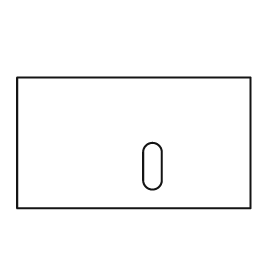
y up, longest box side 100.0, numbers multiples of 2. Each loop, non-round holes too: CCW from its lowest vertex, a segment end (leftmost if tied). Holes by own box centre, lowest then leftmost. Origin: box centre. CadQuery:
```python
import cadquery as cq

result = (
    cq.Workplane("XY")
    .moveTo(-50.0, -28.0)
    .lineTo(50.0, -28.0)
    .lineTo(50.0, 28.0)
    .lineTo(-50.0, 28.0)
    .close()
    .moveTo(4.0, -16.0)
    .threePointArc((8.0, -20.0), (12.0, -16.0))
    .lineTo(12.0, -4.0)
    .threePointArc((8.0, 0.0), (4.0, -4.0))
    .close()
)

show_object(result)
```